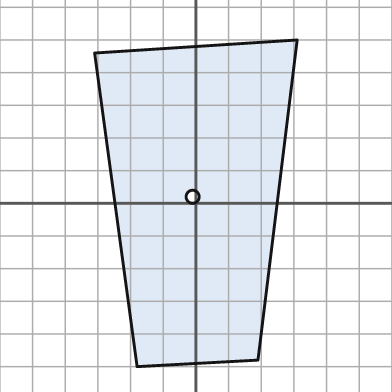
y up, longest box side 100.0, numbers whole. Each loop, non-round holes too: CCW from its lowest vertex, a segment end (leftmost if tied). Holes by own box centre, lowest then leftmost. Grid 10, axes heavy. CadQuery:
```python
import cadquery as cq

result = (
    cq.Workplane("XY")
    .moveTo(-18.0, -50.0)
    .lineTo(19.0, -48.0)
    .lineTo(31.0, 50.0)
    .lineTo(-31.0, 46.0)
    .close()
    .moveTo(-1.0, 2.0)
    .circle(2.0)
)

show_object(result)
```